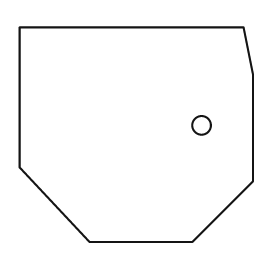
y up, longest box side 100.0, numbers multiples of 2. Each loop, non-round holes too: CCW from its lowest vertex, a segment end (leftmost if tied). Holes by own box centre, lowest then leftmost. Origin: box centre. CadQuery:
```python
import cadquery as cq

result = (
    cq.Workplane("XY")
    .moveTo(-20.0, -46.0)
    .lineTo(24.0, -46.0)
    .lineTo(50.0, -20.0)
    .lineTo(50.0, 26.0)
    .lineTo(46.0, 46.0)
    .lineTo(-50.0, 46.0)
    .lineTo(-50.0, -14.0)
    .close()
    .moveTo(28.0, 4.0)
    .circle(4.0)
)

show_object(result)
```